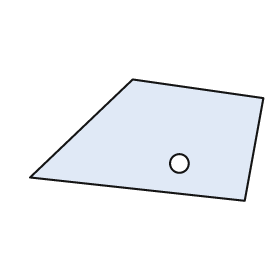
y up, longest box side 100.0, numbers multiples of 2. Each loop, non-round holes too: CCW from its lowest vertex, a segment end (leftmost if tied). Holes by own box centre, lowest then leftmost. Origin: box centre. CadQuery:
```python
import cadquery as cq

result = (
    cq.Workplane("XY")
    .moveTo(42.0, -26.0)
    .lineTo(50.0, 18.0)
    .lineTo(-6.0, 26.0)
    .lineTo(-50.0, -16.0)
    .close()
    .moveTo(14.0, -10.0)
    .circle(4.0)
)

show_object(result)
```